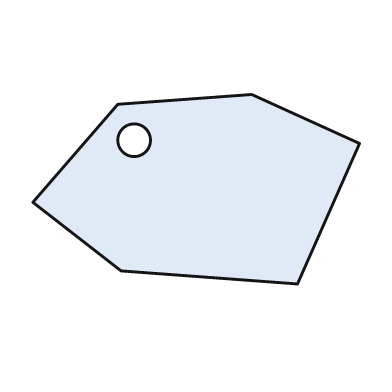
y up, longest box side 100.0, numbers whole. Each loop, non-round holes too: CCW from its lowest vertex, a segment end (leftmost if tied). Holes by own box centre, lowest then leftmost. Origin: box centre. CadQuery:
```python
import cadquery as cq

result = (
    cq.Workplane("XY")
    .moveTo(31.0, -29.0)
    .lineTo(50.0, 14.0)
    .lineTo(17.0, 29.0)
    .lineTo(-24.0, 26.0)
    .lineTo(-50.0, -4.0)
    .lineTo(-23.0, -25.0)
    .close()
    .moveTo(-19.0, 15.0)
    .circle(5.0)
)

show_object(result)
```